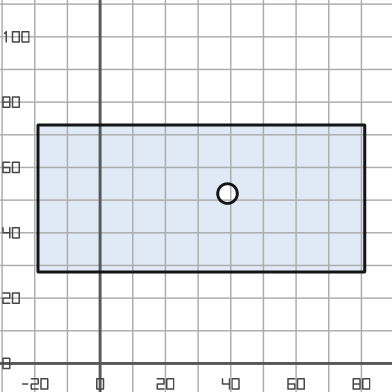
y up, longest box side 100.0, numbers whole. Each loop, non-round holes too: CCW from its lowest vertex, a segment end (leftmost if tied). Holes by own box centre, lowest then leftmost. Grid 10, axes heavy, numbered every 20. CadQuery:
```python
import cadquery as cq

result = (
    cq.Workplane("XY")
    .moveTo(-19.0, 28.0)
    .lineTo(81.0, 28.0)
    .lineTo(81.0, 73.0)
    .lineTo(-19.0, 73.0)
    .close()
    .moveTo(39.0, 52.0)
    .circle(3.0)
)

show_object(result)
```